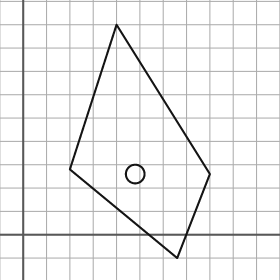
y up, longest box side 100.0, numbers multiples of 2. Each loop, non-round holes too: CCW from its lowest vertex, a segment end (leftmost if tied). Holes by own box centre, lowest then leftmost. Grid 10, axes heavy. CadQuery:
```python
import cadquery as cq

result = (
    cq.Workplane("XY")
    .moveTo(66.0, -10.0)
    .lineTo(80.0, 26.0)
    .lineTo(40.0, 90.0)
    .lineTo(20.0, 28.0)
    .close()
    .moveTo(48.0, 26.0)
    .circle(4.0)
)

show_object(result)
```